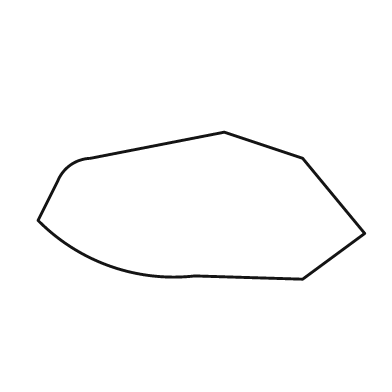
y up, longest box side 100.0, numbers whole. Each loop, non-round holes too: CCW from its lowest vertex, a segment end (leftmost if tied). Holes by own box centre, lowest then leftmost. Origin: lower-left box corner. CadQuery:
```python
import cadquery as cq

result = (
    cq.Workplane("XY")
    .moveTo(81.0, 0.0)
    .lineTo(100.0, 14.0)
    .lineTo(81.0, 37.0)
    .lineTo(57.0, 45.0)
    .lineTo(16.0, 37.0)
    .threePointArc((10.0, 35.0), (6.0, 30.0))
    .lineTo(0.0, 18.0)
    .threePointArc((22.0, 4.0), (48.0, 1.0))
    .close()
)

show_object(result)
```